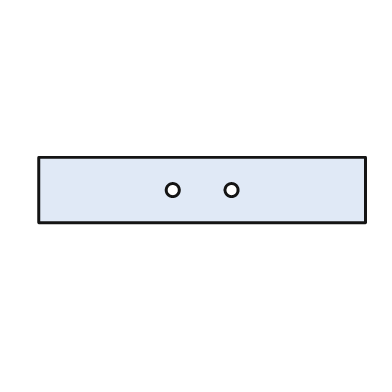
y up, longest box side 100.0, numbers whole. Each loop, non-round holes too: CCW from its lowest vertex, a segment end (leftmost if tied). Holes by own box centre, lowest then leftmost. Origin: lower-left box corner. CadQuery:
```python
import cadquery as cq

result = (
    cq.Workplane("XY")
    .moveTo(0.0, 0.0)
    .lineTo(100.0, 0.0)
    .lineTo(100.0, 20.0)
    .lineTo(0.0, 20.0)
    .close()
    .moveTo(41.0, 10.0)
    .circle(2.0)
    .moveTo(59.0, 10.0)
    .circle(2.0)
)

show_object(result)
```